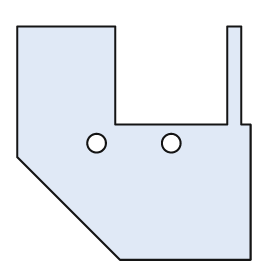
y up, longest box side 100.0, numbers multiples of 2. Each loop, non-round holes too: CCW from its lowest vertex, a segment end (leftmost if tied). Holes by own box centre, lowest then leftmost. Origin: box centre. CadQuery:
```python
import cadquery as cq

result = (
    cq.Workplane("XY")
    .moveTo(-6.0, -50.0)
    .lineTo(50.0, -50.0)
    .lineTo(50.0, 8.0)
    .lineTo(46.0, 8.0)
    .lineTo(46.0, 50.0)
    .lineTo(40.0, 50.0)
    .lineTo(40.0, 8.0)
    .lineTo(-8.0, 8.0)
    .lineTo(-8.0, 50.0)
    .lineTo(-50.0, 50.0)
    .lineTo(-50.0, -6.0)
    .close()
    .moveTo(-16.0, 0.0)
    .circle(4.0)
    .moveTo(16.0, 0.0)
    .circle(4.0)
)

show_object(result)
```